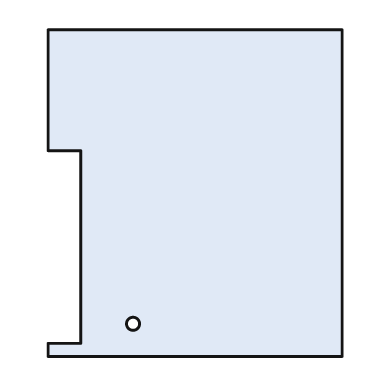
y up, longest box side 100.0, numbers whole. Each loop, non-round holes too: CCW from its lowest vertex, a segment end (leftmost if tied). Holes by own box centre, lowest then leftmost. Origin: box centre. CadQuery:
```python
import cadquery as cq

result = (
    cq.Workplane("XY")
    .moveTo(-45.0, -50.0)
    .lineTo(45.0, -50.0)
    .lineTo(45.0, 50.0)
    .lineTo(-45.0, 50.0)
    .lineTo(-45.0, 13.0)
    .lineTo(-35.0, 13.0)
    .lineTo(-35.0, -46.0)
    .lineTo(-45.0, -46.0)
    .close()
    .moveTo(-19.0, -40.0)
    .circle(2.0)
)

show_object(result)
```